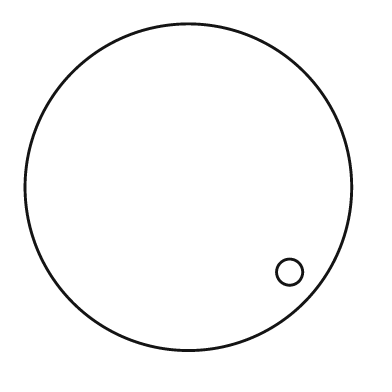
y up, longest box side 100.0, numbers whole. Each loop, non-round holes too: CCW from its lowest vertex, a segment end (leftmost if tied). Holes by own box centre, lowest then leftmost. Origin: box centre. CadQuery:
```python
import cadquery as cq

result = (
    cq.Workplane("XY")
    .moveTo(0.0, 0.0)
    .circle(50.0)
    .moveTo(31.0, -26.0)
    .circle(4.0)
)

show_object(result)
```